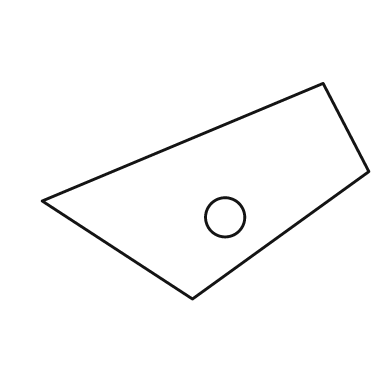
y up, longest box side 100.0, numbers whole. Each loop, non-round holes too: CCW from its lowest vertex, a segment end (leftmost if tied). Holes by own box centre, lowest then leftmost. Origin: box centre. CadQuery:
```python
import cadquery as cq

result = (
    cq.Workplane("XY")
    .moveTo(-4.0, -33.0)
    .lineTo(50.0, 6.0)
    .lineTo(36.0, 33.0)
    .lineTo(-50.0, -3.0)
    .close()
    .moveTo(6.0, -8.0)
    .circle(6.0)
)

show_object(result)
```